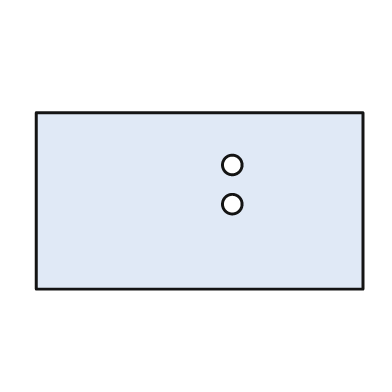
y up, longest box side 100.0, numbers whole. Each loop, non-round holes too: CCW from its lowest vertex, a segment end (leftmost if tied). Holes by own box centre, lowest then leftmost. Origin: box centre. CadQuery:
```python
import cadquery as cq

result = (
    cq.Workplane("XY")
    .moveTo(-50.0, -27.0)
    .lineTo(50.0, -27.0)
    .lineTo(50.0, 27.0)
    .lineTo(-50.0, 27.0)
    .close()
    .moveTo(10.0, -1.0)
    .circle(3.0)
    .moveTo(10.0, 11.0)
    .circle(3.0)
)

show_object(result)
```